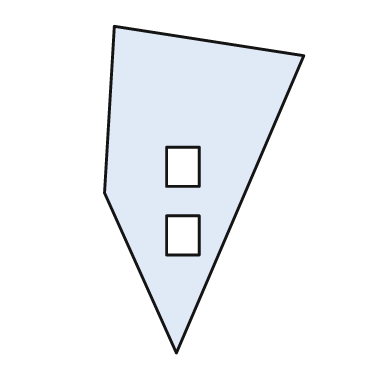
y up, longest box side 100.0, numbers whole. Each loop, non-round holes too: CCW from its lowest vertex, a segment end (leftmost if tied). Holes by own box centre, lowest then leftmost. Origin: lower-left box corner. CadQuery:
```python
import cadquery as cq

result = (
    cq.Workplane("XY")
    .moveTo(22.0, 0.0)
    .lineTo(61.0, 91.0)
    .lineTo(3.0, 100.0)
    .lineTo(0.0, 49.0)
    .close()
    .moveTo(19.0, 30.0)
    .lineTo(29.0, 30.0)
    .lineTo(29.0, 42.0)
    .lineTo(19.0, 42.0)
    .close()
    .moveTo(19.0, 51.0)
    .lineTo(29.0, 51.0)
    .lineTo(29.0, 63.0)
    .lineTo(19.0, 63.0)
    .close()
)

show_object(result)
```